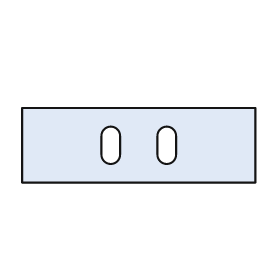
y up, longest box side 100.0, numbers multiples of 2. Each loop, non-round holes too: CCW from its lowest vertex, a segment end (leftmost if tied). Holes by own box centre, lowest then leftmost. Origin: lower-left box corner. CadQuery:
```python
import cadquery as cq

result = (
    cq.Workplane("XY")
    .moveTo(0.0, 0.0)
    .lineTo(100.0, 0.0)
    .lineTo(100.0, 32.0)
    .lineTo(0.0, 32.0)
    .close()
    .moveTo(34.0, 12.0)
    .threePointArc((38.0, 8.0), (42.0, 12.0))
    .lineTo(42.0, 20.0)
    .threePointArc((38.0, 24.0), (34.0, 20.0))
    .close()
    .moveTo(58.0, 12.0)
    .threePointArc((62.0, 8.0), (66.0, 12.0))
    .lineTo(66.0, 20.0)
    .threePointArc((62.0, 24.0), (58.0, 20.0))
    .close()
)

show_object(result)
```